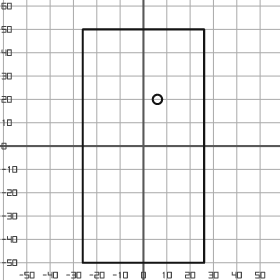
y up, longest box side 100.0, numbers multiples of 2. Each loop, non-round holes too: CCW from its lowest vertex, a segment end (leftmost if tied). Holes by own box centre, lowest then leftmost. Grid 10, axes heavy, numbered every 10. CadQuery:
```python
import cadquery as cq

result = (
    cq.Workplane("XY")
    .moveTo(-26.0, -50.0)
    .lineTo(26.0, -50.0)
    .lineTo(26.0, 50.0)
    .lineTo(-26.0, 50.0)
    .close()
    .moveTo(6.0, 20.0)
    .circle(2.0)
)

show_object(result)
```